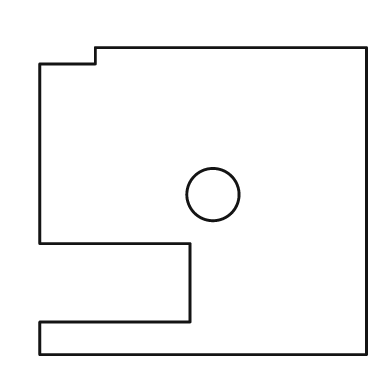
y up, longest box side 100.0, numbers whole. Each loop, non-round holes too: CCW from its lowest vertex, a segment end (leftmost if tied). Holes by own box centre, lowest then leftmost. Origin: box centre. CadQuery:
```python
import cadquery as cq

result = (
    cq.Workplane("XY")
    .moveTo(-50.0, -47.0)
    .lineTo(50.0, -47.0)
    .lineTo(50.0, 47.0)
    .lineTo(-33.0, 47.0)
    .lineTo(-33.0, 42.0)
    .lineTo(-50.0, 42.0)
    .lineTo(-50.0, -13.0)
    .lineTo(-4.0, -13.0)
    .lineTo(-4.0, -37.0)
    .lineTo(-50.0, -37.0)
    .close()
    .moveTo(3.0, 2.0)
    .circle(8.0)
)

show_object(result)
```